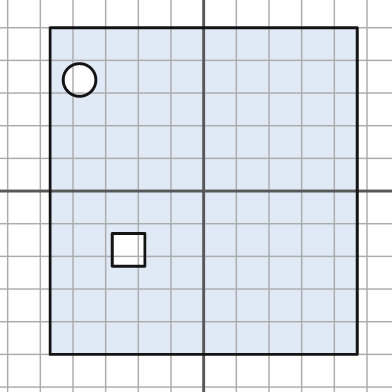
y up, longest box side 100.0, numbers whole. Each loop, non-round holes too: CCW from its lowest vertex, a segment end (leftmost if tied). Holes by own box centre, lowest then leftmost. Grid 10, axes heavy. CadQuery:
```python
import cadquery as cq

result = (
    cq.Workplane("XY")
    .moveTo(-47.0, -50.0)
    .lineTo(47.0, -50.0)
    .lineTo(47.0, 50.0)
    .lineTo(-47.0, 50.0)
    .close()
    .moveTo(-28.0, -23.0)
    .lineTo(-18.0, -23.0)
    .lineTo(-18.0, -13.0)
    .lineTo(-28.0, -13.0)
    .close()
    .moveTo(-38.0, 34.0)
    .circle(5.0)
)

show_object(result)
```